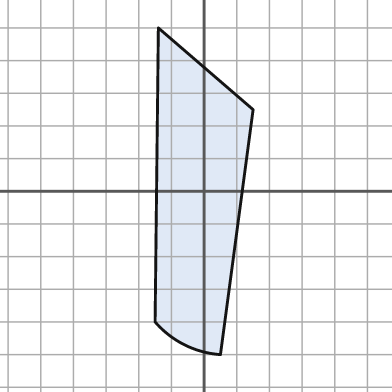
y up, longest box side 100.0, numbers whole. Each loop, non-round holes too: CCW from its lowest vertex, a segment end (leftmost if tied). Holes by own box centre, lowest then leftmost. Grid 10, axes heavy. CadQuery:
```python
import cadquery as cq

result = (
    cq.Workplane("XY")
    .moveTo(5.0, -50.0)
    .lineTo(15.0, 25.0)
    .lineTo(-14.0, 50.0)
    .lineTo(-15.0, -40.0)
    .threePointArc((-6.0, -47.0), (5.0, -50.0))
    .close()
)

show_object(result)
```